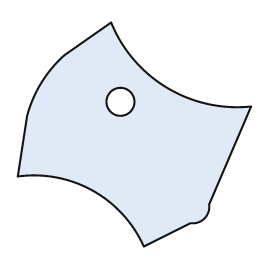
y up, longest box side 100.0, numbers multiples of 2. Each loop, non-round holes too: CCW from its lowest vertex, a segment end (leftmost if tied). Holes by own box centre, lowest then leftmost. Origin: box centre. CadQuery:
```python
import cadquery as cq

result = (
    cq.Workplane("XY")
    .moveTo(4.0, -48.0)
    .lineTo(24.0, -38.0)
    .threePointArc((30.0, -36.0), (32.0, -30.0))
    .lineTo(50.0, 12.0)
    .threePointArc((14.0, 20.0), (-10.0, 48.0))
    .lineTo(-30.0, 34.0)
    .threePointArc((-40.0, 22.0), (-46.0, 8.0))
    .lineTo(-50.0, -18.0)
    .threePointArc((-18.0, -24.0), (4.0, -48.0))
    .close()
    .moveTo(-6.0, 14.0)
    .circle(6.0)
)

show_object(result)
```